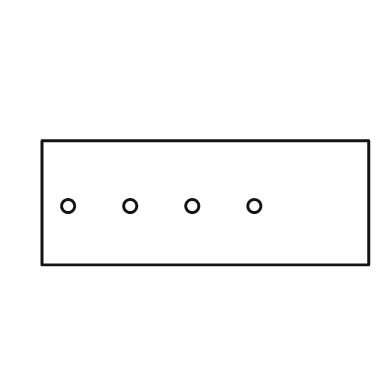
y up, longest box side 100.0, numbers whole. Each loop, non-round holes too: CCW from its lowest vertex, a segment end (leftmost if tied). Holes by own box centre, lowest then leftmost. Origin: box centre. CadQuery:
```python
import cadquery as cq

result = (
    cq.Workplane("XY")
    .moveTo(-50.0, -19.0)
    .lineTo(50.0, -19.0)
    .lineTo(50.0, 19.0)
    .lineTo(-50.0, 19.0)
    .close()
    .moveTo(-42.0, -1.0)
    .circle(2.0)
    .moveTo(-23.0, -1.0)
    .circle(2.0)
    .moveTo(-4.0, -1.0)
    .circle(2.0)
    .moveTo(15.0, -1.0)
    .circle(2.0)
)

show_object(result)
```